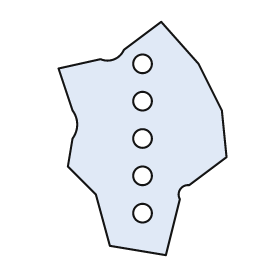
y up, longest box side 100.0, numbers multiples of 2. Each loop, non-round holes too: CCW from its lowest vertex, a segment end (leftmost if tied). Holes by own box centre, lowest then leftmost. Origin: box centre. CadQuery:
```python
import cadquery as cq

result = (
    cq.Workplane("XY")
    .moveTo(10.0, -50.0)
    .lineTo(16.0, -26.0)
    .threePointArc((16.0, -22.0), (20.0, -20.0))
    .lineTo(36.0, -8.0)
    .lineTo(34.0, 12.0)
    .lineTo(24.0, 32.0)
    .lineTo(8.0, 50.0)
    .lineTo(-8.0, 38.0)
    .threePointArc((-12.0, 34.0), (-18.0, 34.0))
    .lineTo(-36.0, 30.0)
    .lineTo(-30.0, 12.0)
    .threePointArc((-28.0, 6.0), (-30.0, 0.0))
    .lineTo(-32.0, -12.0)
    .lineTo(-20.0, -24.0)
    .lineTo(-14.0, -46.0)
    .close()
    .moveTo(0.0, -32.0)
    .circle(4.0)
    .moveTo(0.0, -16.0)
    .circle(4.0)
    .moveTo(0.0, 0.0)
    .circle(4.0)
    .moveTo(0.0, 16.0)
    .circle(4.0)
    .moveTo(0.0, 32.0)
    .circle(4.0)
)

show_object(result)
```